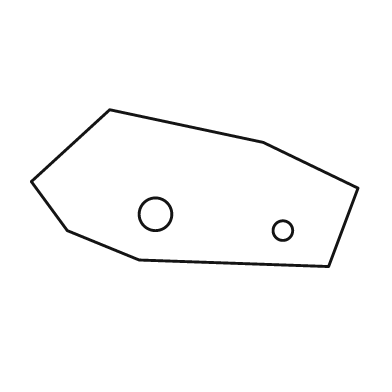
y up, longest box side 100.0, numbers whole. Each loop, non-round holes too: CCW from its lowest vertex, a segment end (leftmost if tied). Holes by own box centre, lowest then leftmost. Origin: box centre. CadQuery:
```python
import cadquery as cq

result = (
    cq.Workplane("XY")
    .moveTo(41.0, -24.0)
    .lineTo(50.0, 0.0)
    .lineTo(21.0, 14.0)
    .lineTo(-26.0, 24.0)
    .lineTo(-50.0, 2.0)
    .lineTo(-39.0, -13.0)
    .lineTo(-17.0, -22.0)
    .close()
    .moveTo(27.0, -13.0)
    .circle(3.0)
    .moveTo(-12.0, -8.0)
    .circle(5.0)
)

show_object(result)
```